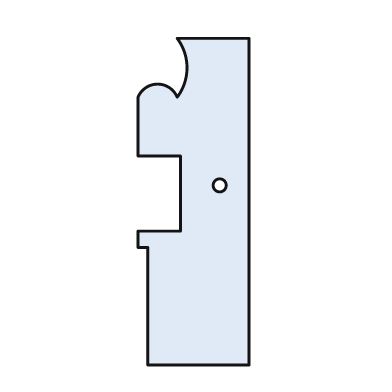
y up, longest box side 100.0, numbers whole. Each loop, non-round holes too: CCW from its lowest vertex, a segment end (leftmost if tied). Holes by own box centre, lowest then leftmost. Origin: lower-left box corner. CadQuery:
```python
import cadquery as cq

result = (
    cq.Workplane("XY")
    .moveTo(3.0, 0.0)
    .lineTo(34.0, 0.0)
    .lineTo(34.0, 100.0)
    .lineTo(12.0, 100.0)
    .threePointArc((15.0, 91.0), (12.0, 82.0))
    .threePointArc((6.0, 86.0), (0.0, 82.0))
    .lineTo(0.0, 64.0)
    .lineTo(13.0, 64.0)
    .lineTo(13.0, 41.0)
    .lineTo(0.0, 41.0)
    .lineTo(0.0, 36.0)
    .lineTo(3.0, 36.0)
    .close()
    .moveTo(25.0, 55.0)
    .circle(2.0)
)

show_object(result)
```